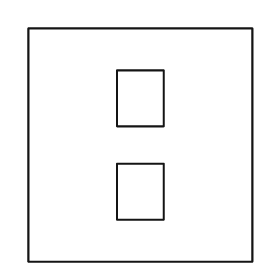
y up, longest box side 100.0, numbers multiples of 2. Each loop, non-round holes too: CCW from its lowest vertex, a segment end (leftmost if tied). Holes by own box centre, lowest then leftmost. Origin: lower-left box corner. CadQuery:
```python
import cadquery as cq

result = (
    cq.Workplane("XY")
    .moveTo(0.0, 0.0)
    .lineTo(96.0, 0.0)
    .lineTo(96.0, 100.0)
    .lineTo(0.0, 100.0)
    .close()
    .moveTo(38.0, 18.0)
    .lineTo(58.0, 18.0)
    .lineTo(58.0, 42.0)
    .lineTo(38.0, 42.0)
    .close()
    .moveTo(38.0, 58.0)
    .lineTo(58.0, 58.0)
    .lineTo(58.0, 82.0)
    .lineTo(38.0, 82.0)
    .close()
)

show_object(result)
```